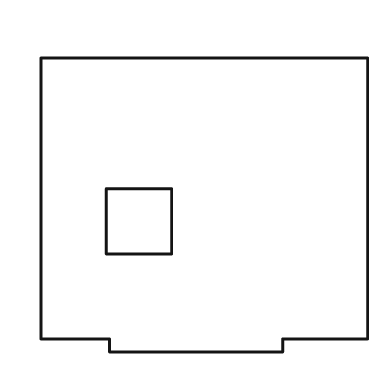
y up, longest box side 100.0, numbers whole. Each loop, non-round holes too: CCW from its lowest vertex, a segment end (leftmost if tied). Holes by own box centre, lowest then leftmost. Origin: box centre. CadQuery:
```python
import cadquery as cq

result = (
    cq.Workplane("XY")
    .moveTo(-29.0, -45.0)
    .lineTo(24.0, -45.0)
    .lineTo(24.0, -41.0)
    .lineTo(50.0, -41.0)
    .lineTo(50.0, 45.0)
    .lineTo(-50.0, 45.0)
    .lineTo(-50.0, -41.0)
    .lineTo(-29.0, -41.0)
    .close()
    .moveTo(-30.0, -15.0)
    .lineTo(-10.0, -15.0)
    .lineTo(-10.0, 5.0)
    .lineTo(-30.0, 5.0)
    .close()
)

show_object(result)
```